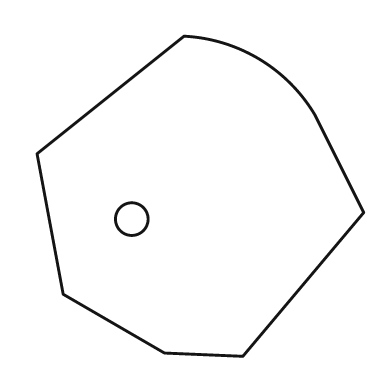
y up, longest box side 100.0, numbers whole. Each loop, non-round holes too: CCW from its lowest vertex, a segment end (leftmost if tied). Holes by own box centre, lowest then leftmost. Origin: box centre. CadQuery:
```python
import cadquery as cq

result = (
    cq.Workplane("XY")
    .moveTo(13.0, -49.0)
    .lineTo(50.0, -5.0)
    .lineTo(35.0, 25.0)
    .threePointArc((18.0, 42.0), (-5.0, 49.0))
    .lineTo(-50.0, 13.0)
    .lineTo(-42.0, -30.0)
    .lineTo(-11.0, -48.0)
    .close()
    .moveTo(-21.0, -7.0)
    .circle(5.0)
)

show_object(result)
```